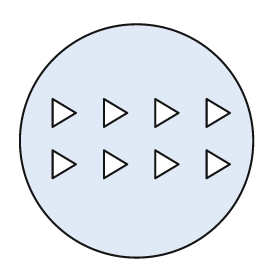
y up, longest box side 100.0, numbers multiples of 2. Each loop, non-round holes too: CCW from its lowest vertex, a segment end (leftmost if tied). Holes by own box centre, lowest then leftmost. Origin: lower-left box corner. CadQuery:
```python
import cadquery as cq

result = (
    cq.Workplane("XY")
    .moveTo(50.0, 50.0)
    .circle(50.0)
    .moveTo(14.0, 34.0)
    .lineTo(24.0, 40.0)
    .lineTo(14.0, 46.0)
    .close()
    .moveTo(36.0, 34.0)
    .lineTo(46.0, 40.0)
    .lineTo(36.0, 46.0)
    .close()
    .moveTo(58.0, 34.0)
    .lineTo(68.0, 40.0)
    .lineTo(58.0, 46.0)
    .close()
    .moveTo(80.0, 34.0)
    .lineTo(90.0, 40.0)
    .lineTo(80.0, 46.0)
    .close()
    .moveTo(14.0, 56.0)
    .lineTo(24.0, 62.0)
    .lineTo(14.0, 68.0)
    .close()
    .moveTo(36.0, 56.0)
    .lineTo(46.0, 62.0)
    .lineTo(36.0, 68.0)
    .close()
    .moveTo(58.0, 56.0)
    .lineTo(68.0, 62.0)
    .lineTo(58.0, 68.0)
    .close()
    .moveTo(80.0, 56.0)
    .lineTo(90.0, 62.0)
    .lineTo(80.0, 68.0)
    .close()
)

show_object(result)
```